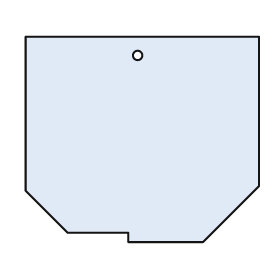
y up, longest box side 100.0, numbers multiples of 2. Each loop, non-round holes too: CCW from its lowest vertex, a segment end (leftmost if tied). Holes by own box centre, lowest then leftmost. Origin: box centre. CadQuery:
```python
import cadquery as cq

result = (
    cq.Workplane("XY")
    .moveTo(-6.0, -44.0)
    .lineTo(26.0, -44.0)
    .lineTo(50.0, -20.0)
    .lineTo(50.0, 44.0)
    .lineTo(-50.0, 44.0)
    .lineTo(-50.0, -22.0)
    .lineTo(-32.0, -40.0)
    .lineTo(-6.0, -40.0)
    .close()
    .moveTo(-2.0, 36.0)
    .circle(2.0)
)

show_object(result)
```